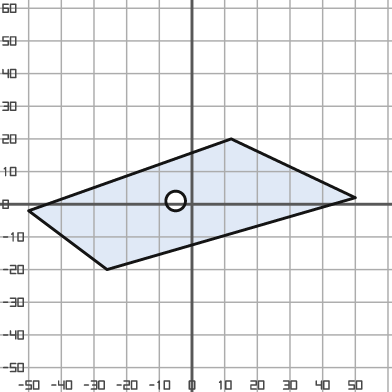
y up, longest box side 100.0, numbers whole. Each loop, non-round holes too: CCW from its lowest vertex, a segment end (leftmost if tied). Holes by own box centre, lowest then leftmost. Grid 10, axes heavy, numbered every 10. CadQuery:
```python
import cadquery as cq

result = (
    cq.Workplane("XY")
    .moveTo(-26.0, -20.0)
    .lineTo(50.0, 2.0)
    .lineTo(12.0, 20.0)
    .lineTo(-50.0, -2.0)
    .close()
    .moveTo(-5.0, 1.0)
    .circle(3.0)
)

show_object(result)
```